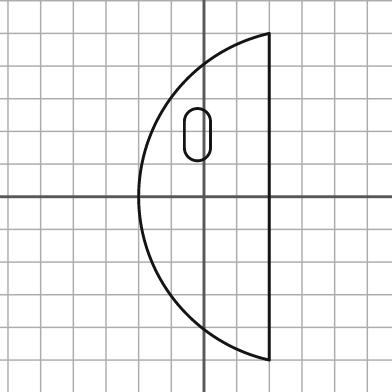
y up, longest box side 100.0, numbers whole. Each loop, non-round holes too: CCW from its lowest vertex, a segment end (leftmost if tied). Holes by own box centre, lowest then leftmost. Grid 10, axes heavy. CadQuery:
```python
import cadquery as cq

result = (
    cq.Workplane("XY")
    .moveTo(20.0, -50.0)
    .lineTo(20.0, 50.0)
    .threePointArc((-20.0, 0.0), (20.0, -50.0))
    .close()
    .moveTo(-6.0, 15.0)
    .threePointArc((-2.0, 11.0), (2.0, 15.0))
    .lineTo(2.0, 23.0)
    .threePointArc((-2.0, 27.0), (-6.0, 23.0))
    .close()
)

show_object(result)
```